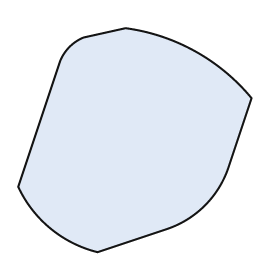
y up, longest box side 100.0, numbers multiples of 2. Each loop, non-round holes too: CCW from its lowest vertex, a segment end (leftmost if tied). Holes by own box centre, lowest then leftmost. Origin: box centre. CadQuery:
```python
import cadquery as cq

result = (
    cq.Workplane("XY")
    .moveTo(-16.0, -48.0)
    .lineTo(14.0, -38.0)
    .threePointArc((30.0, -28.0), (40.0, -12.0))
    .lineTo(50.0, 18.0)
    .threePointArc((26.0, 38.0), (-4.0, 48.0))
    .lineTo(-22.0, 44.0)
    .threePointArc((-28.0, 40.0), (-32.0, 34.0))
    .lineTo(-50.0, -20.0)
    .threePointArc((-36.0, -38.0), (-16.0, -48.0))
    .close()
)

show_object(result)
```